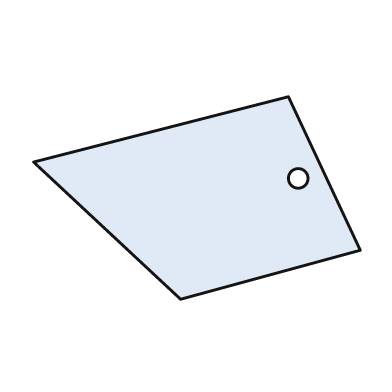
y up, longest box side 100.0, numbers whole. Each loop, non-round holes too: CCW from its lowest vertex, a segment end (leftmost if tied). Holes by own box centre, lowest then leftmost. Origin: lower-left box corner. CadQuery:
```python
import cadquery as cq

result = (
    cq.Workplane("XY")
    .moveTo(45.0, 0.0)
    .lineTo(100.0, 15.0)
    .lineTo(78.0, 62.0)
    .lineTo(0.0, 42.0)
    .close()
    .moveTo(81.0, 37.0)
    .circle(3.0)
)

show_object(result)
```